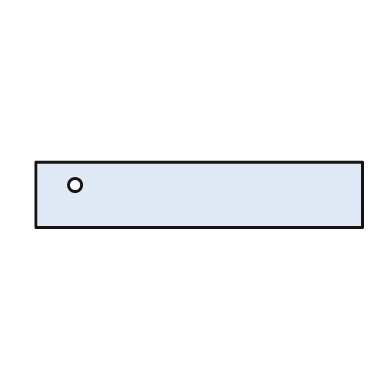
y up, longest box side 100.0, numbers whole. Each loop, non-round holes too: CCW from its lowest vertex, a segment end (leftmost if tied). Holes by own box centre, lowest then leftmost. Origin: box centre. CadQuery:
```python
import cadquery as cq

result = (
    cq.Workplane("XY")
    .moveTo(-50.0, -10.0)
    .lineTo(50.0, -10.0)
    .lineTo(50.0, 10.0)
    .lineTo(-50.0, 10.0)
    .close()
    .moveTo(-38.0, 3.0)
    .circle(2.0)
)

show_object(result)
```